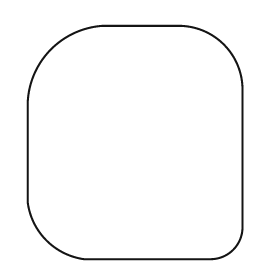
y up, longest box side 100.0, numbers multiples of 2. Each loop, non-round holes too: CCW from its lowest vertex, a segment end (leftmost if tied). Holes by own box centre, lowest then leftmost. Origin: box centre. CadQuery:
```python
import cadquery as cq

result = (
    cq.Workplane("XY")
    .moveTo(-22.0, -50.0)
    .lineTo(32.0, -50.0)
    .threePointArc((42.0, -46.0), (46.0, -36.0))
    .lineTo(46.0, 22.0)
    .threePointArc((38.0, 42.0), (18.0, 50.0))
    .lineTo(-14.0, 50.0)
    .threePointArc((-36.0, 40.0), (-46.0, 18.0))
    .lineTo(-46.0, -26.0)
    .threePointArc((-38.0, -42.0), (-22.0, -50.0))
    .close()
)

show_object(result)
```